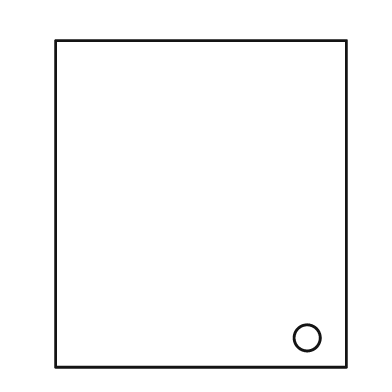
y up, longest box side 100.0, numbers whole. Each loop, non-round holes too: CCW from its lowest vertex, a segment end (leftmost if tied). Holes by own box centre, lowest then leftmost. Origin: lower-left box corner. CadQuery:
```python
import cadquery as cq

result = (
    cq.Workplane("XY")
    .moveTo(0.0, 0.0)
    .lineTo(89.0, 0.0)
    .lineTo(89.0, 100.0)
    .lineTo(0.0, 100.0)
    .close()
    .moveTo(77.0, 9.0)
    .circle(4.0)
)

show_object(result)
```